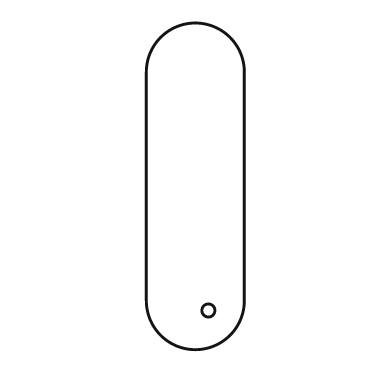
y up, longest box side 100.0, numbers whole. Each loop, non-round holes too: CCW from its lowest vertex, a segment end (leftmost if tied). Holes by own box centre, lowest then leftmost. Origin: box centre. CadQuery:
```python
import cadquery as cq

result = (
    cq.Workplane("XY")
    .moveTo(-15.0, -35.0)
    .threePointArc((0.0, -50.0), (15.0, -35.0))
    .lineTo(15.0, 35.0)
    .threePointArc((0.0, 50.0), (-15.0, 35.0))
    .close()
    .moveTo(4.0, -38.0)
    .circle(2.0)
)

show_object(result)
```